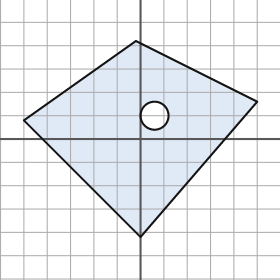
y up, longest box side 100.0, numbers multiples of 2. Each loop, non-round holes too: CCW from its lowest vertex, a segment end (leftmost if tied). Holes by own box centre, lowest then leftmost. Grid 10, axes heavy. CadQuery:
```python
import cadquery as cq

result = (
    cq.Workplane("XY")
    .moveTo(0.0, -42.0)
    .lineTo(50.0, 16.0)
    .lineTo(-2.0, 42.0)
    .lineTo(-50.0, 8.0)
    .close()
    .moveTo(6.0, 10.0)
    .circle(6.0)
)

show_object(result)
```